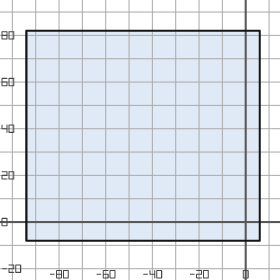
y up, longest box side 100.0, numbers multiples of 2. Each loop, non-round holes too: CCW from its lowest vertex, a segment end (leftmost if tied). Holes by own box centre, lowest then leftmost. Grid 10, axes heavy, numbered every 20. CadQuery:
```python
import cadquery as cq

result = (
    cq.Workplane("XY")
    .moveTo(-94.0, -8.0)
    .lineTo(6.0, -8.0)
    .lineTo(6.0, 82.0)
    .lineTo(-94.0, 82.0)
    .close()
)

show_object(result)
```